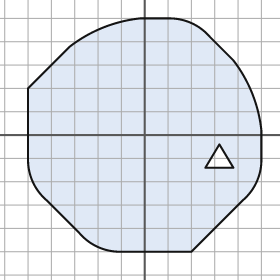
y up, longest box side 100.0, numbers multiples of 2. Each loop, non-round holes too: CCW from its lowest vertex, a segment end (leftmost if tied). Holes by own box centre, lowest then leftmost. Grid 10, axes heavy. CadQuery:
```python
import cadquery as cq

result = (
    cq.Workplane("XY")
    .moveTo(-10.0, -50.0)
    .lineTo(20.0, -50.0)
    .lineTo(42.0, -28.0)
    .threePointArc((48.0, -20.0), (50.0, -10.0))
    .lineTo(50.0, 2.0)
    .threePointArc((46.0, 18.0), (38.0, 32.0))
    .lineTo(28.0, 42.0)
    .threePointArc((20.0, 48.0), (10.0, 50.0))
    .lineTo(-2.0, 50.0)
    .threePointArc((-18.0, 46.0), (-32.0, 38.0))
    .lineTo(-50.0, 20.0)
    .lineTo(-50.0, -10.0)
    .threePointArc((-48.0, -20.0), (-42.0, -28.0))
    .lineTo(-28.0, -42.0)
    .threePointArc((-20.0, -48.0), (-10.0, -50.0))
    .close()
    .moveTo(26.0, -14.0)
    .lineTo(38.0, -14.0)
    .lineTo(32.0, -4.0)
    .close()
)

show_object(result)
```